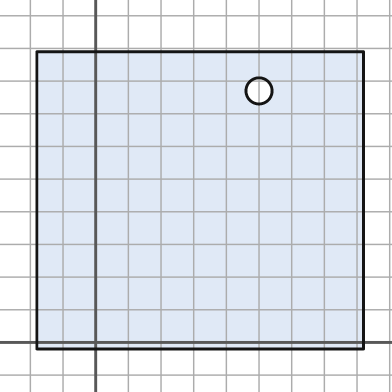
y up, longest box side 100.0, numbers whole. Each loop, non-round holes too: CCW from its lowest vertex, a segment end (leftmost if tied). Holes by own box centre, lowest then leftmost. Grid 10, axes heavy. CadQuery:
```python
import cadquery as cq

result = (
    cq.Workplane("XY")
    .moveTo(-18.0, -2.0)
    .lineTo(82.0, -2.0)
    .lineTo(82.0, 89.0)
    .lineTo(-18.0, 89.0)
    .close()
    .moveTo(50.0, 77.0)
    .circle(4.0)
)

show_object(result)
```